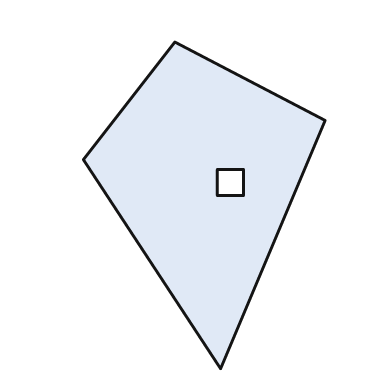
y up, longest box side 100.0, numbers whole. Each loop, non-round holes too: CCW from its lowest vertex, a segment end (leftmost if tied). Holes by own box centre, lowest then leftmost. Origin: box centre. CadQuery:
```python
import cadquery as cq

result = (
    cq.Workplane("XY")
    .moveTo(5.0, -50.0)
    .lineTo(37.0, 26.0)
    .lineTo(-9.0, 50.0)
    .lineTo(-37.0, 14.0)
    .close()
    .moveTo(4.0, 3.0)
    .lineTo(12.0, 3.0)
    .lineTo(12.0, 11.0)
    .lineTo(4.0, 11.0)
    .close()
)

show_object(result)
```